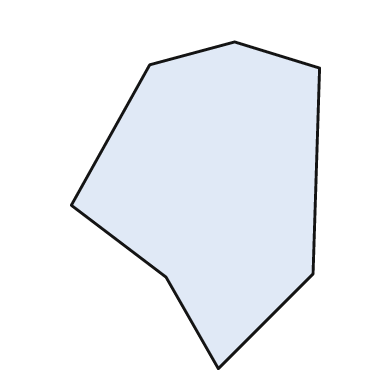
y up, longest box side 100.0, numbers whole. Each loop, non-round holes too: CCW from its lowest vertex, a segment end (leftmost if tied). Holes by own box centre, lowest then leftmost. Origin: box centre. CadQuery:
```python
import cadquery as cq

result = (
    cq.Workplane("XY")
    .moveTo(7.0, -50.0)
    .lineTo(36.0, -21.0)
    .lineTo(38.0, 42.0)
    .lineTo(12.0, 50.0)
    .lineTo(-14.0, 43.0)
    .lineTo(-38.0, 0.0)
    .lineTo(-9.0, -22.0)
    .close()
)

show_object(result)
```